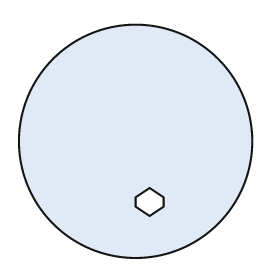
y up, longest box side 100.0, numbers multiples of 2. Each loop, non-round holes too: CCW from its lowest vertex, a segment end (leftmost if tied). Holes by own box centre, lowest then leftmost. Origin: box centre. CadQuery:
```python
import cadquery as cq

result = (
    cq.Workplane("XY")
    .moveTo(0.0, 0.0)
    .circle(50.0)
    .moveTo(6.0, -32.0)
    .lineTo(12.0, -28.0)
    .lineTo(12.0, -24.0)
    .lineTo(6.0, -20.0)
    .lineTo(0.0, -24.0)
    .lineTo(0.0, -28.0)
    .close()
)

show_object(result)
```